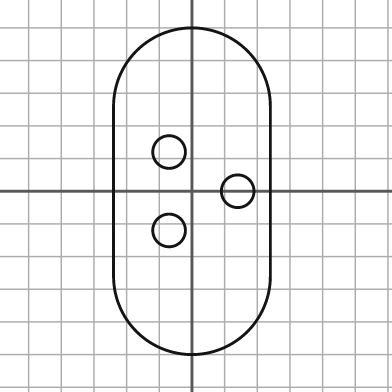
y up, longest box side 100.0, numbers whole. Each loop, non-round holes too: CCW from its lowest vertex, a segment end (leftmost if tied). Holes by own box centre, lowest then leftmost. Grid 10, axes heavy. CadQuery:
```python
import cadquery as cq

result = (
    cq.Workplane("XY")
    .moveTo(-24.0, -26.0)
    .threePointArc((0.0, -50.0), (24.0, -26.0))
    .lineTo(24.0, 26.0)
    .threePointArc((0.0, 50.0), (-24.0, 26.0))
    .close()
    .moveTo(-7.0, -12.0)
    .circle(5.0)
    .moveTo(14.0, 0.0)
    .circle(5.0)
    .moveTo(-7.0, 12.0)
    .circle(5.0)
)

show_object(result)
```